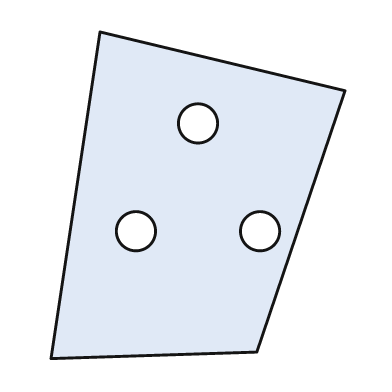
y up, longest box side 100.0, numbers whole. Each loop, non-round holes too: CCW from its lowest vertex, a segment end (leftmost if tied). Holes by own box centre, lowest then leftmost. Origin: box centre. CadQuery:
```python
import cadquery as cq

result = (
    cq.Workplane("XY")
    .moveTo(-45.0, -50.0)
    .lineTo(18.0, -48.0)
    .lineTo(45.0, 32.0)
    .lineTo(-30.0, 50.0)
    .close()
    .moveTo(-19.0, -11.0)
    .circle(6.0)
    .moveTo(19.0, -11.0)
    .circle(6.0)
    .moveTo(0.0, 22.0)
    .circle(6.0)
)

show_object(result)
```